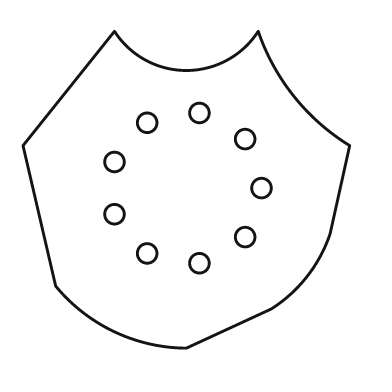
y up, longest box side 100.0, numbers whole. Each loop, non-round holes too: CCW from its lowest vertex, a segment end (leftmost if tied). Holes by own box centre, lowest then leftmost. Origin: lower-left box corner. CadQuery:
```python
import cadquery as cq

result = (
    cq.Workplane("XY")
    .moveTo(50.0, 0.0)
    .lineTo(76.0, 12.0)
    .threePointArc((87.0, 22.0), (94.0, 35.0))
    .lineTo(100.0, 62.0)
    .threePointArc((83.0, 77.0), (72.0, 97.0))
    .threePointArc((50.0, 85.0), (28.0, 97.0))
    .lineTo(0.0, 62.0)
    .lineTo(10.0, 19.0)
    .threePointArc((28.0, 5.0), (50.0, 0.0))
    .close()
    .moveTo(54.0, 26.0)
    .circle(3.0)
    .moveTo(38.0, 29.0)
    .circle(3.0)
    .moveTo(68.0, 34.0)
    .circle(3.0)
    .moveTo(28.0, 41.0)
    .circle(3.0)
    .moveTo(73.0, 49.0)
    .circle(3.0)
    .moveTo(28.0, 57.0)
    .circle(3.0)
    .moveTo(68.0, 64.0)
    .circle(3.0)
    .moveTo(38.0, 69.0)
    .circle(3.0)
    .moveTo(54.0, 72.0)
    .circle(3.0)
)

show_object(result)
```